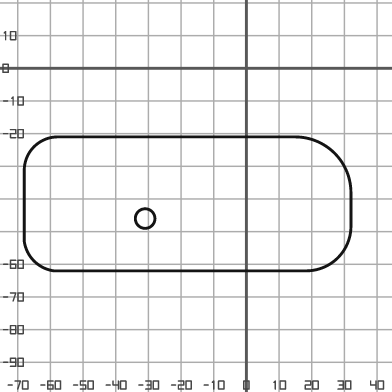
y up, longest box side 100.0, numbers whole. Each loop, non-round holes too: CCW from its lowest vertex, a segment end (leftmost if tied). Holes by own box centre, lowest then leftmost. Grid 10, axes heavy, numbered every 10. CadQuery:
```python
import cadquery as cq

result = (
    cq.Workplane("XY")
    .moveTo(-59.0, -62.0)
    .lineTo(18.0, -62.0)
    .threePointArc((28.0, -58.0), (32.0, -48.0))
    .lineTo(32.0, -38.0)
    .threePointArc((27.0, -26.0), (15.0, -21.0))
    .lineTo(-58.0, -21.0)
    .threePointArc((-65.0, -24.0), (-68.0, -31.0))
    .lineTo(-68.0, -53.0)
    .threePointArc((-65.0, -59.0), (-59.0, -62.0))
    .close()
    .moveTo(-31.0, -46.0)
    .circle(3.0)
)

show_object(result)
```